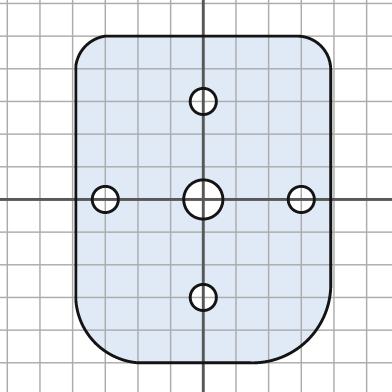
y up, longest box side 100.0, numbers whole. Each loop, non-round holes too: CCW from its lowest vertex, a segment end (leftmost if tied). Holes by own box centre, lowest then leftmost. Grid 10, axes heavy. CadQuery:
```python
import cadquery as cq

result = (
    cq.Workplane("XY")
    .moveTo(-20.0, -50.0)
    .lineTo(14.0, -50.0)
    .threePointArc((32.0, -43.0), (39.0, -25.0))
    .lineTo(39.0, 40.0)
    .threePointArc((36.0, 47.0), (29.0, 50.0))
    .lineTo(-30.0, 50.0)
    .threePointArc((-36.0, 47.0), (-39.0, 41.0))
    .lineTo(-39.0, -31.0)
    .threePointArc((-33.0, -44.0), (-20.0, -50.0))
    .close()
    .moveTo(0.0, -30.0)
    .circle(4.0)
    .moveTo(-30.0, 0.0)
    .circle(4.0)
    .moveTo(0.0, 0.0)
    .circle(6.0)
    .moveTo(30.0, 0.0)
    .circle(4.0)
    .moveTo(0.0, 30.0)
    .circle(4.0)
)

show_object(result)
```